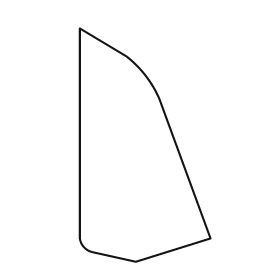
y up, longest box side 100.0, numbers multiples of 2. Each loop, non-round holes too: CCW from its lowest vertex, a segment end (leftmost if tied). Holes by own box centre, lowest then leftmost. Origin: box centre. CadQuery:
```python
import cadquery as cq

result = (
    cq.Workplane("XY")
    .moveTo(-4.0, -50.0)
    .lineTo(28.0, -40.0)
    .lineTo(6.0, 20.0)
    .threePointArc((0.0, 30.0), (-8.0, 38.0))
    .lineTo(-28.0, 50.0)
    .lineTo(-28.0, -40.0)
    .threePointArc((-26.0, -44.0), (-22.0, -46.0))
    .close()
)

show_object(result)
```